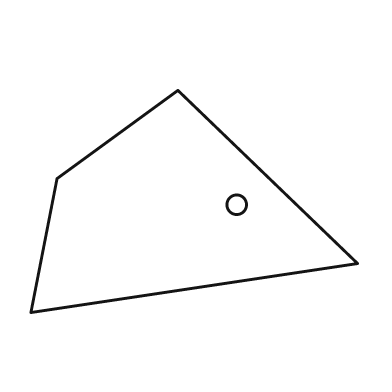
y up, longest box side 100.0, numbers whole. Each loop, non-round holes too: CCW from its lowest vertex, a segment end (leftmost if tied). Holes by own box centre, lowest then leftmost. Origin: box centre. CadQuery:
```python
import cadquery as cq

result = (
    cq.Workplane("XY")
    .moveTo(-50.0, -34.0)
    .lineTo(50.0, -19.0)
    .lineTo(-5.0, 34.0)
    .lineTo(-42.0, 7.0)
    .close()
    .moveTo(13.0, -1.0)
    .circle(3.0)
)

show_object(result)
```